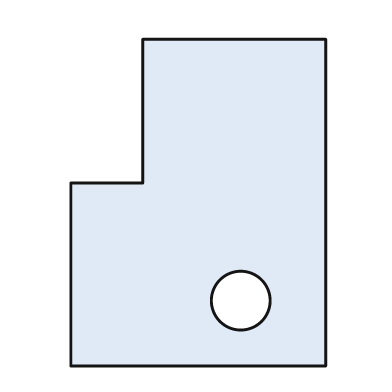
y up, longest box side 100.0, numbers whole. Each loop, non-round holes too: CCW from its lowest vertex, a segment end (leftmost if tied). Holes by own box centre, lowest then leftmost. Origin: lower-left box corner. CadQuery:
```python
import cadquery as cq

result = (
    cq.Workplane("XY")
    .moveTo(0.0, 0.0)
    .lineTo(78.0, 0.0)
    .lineTo(78.0, 100.0)
    .lineTo(22.0, 100.0)
    .lineTo(22.0, 56.0)
    .lineTo(0.0, 56.0)
    .close()
    .moveTo(52.0, 20.0)
    .circle(9.0)
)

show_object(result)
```